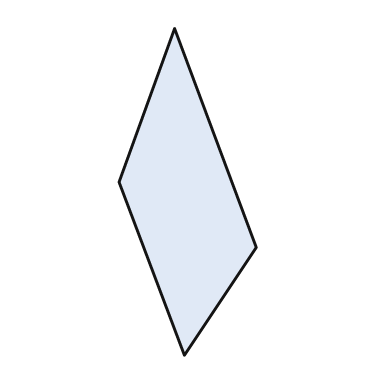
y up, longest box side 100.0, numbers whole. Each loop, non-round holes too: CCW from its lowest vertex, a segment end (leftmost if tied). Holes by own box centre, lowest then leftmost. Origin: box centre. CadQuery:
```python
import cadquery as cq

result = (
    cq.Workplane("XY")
    .moveTo(-1.0, -50.0)
    .lineTo(21.0, -17.0)
    .lineTo(-4.0, 50.0)
    .lineTo(-21.0, 3.0)
    .close()
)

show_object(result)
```